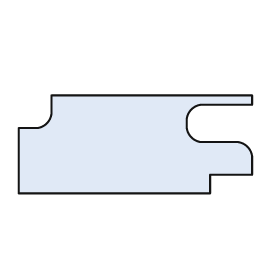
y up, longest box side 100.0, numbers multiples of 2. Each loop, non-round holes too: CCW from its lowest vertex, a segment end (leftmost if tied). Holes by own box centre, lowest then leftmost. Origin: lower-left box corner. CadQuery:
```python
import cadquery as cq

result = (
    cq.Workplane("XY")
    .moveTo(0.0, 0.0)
    .lineTo(82.0, 0.0)
    .lineTo(82.0, 8.0)
    .lineTo(100.0, 8.0)
    .lineTo(100.0, 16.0)
    .threePointArc((98.0, 20.0), (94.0, 22.0))
    .lineTo(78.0, 22.0)
    .threePointArc((74.0, 24.0), (72.0, 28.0))
    .lineTo(72.0, 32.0)
    .threePointArc((74.0, 36.0), (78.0, 38.0))
    .lineTo(100.0, 38.0)
    .lineTo(100.0, 42.0)
    .lineTo(14.0, 42.0)
    .lineTo(14.0, 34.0)
    .threePointArc((12.0, 30.0), (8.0, 28.0))
    .lineTo(0.0, 28.0)
    .close()
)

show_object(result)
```